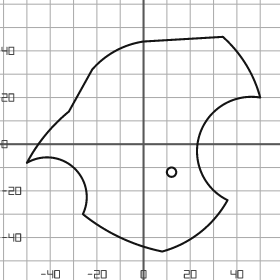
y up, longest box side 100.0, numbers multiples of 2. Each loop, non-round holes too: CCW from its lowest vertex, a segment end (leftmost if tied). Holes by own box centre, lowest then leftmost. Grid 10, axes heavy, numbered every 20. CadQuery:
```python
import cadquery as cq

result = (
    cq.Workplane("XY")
    .moveTo(8.0, -46.0)
    .threePointArc((24.0, -38.0), (36.0, -24.0))
    .threePointArc((24.0, 4.0), (50.0, 20.0))
    .threePointArc((44.0, 34.0), (34.0, 46.0))
    .lineTo(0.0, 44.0)
    .threePointArc((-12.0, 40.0), (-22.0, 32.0))
    .lineTo(-32.0, 14.0)
    .threePointArc((-42.0, 4.0), (-50.0, -8.0))
    .threePointArc((-30.0, -10.0), (-26.0, -30.0))
    .threePointArc((-10.0, -40.0), (8.0, -46.0))
    .close()
    .moveTo(12.0, -12.0)
    .circle(2.0)
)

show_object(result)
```